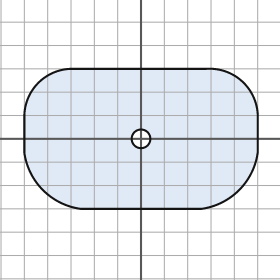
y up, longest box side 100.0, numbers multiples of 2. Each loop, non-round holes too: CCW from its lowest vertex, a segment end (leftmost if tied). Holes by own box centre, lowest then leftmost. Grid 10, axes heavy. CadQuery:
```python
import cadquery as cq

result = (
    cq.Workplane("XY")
    .moveTo(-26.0, -30.0)
    .lineTo(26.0, -30.0)
    .threePointArc((42.0, -22.0), (50.0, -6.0))
    .lineTo(50.0, 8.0)
    .threePointArc((44.0, 24.0), (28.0, 30.0))
    .lineTo(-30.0, 30.0)
    .threePointArc((-44.0, 24.0), (-50.0, 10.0))
    .lineTo(-50.0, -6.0)
    .threePointArc((-42.0, -22.0), (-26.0, -30.0))
    .close()
    .moveTo(0.0, 0.0)
    .circle(4.0)
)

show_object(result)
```